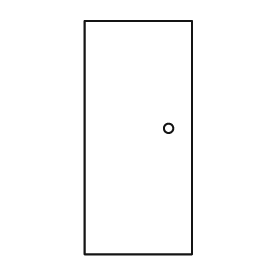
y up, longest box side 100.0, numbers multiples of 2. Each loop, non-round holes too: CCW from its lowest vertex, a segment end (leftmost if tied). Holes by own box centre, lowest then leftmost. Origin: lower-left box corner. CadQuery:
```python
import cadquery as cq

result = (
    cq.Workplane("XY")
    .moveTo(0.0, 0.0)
    .lineTo(46.0, 0.0)
    .lineTo(46.0, 100.0)
    .lineTo(0.0, 100.0)
    .close()
    .moveTo(36.0, 54.0)
    .circle(2.0)
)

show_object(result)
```